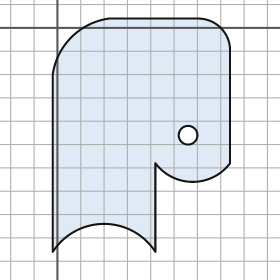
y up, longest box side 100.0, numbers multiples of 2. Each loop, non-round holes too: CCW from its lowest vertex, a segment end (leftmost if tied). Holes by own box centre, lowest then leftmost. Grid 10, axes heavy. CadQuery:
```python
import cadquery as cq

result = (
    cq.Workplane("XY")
    .moveTo(-2.0, -96.0)
    .threePointArc((20.0, -84.0), (42.0, -96.0))
    .lineTo(42.0, -58.0)
    .threePointArc((58.0, -66.0), (74.0, -58.0))
    .lineTo(74.0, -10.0)
    .threePointArc((70.0, 0.0), (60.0, 4.0))
    .lineTo(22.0, 4.0)
    .threePointArc((6.0, -4.0), (-2.0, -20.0))
    .close()
    .moveTo(56.0, -46.0)
    .circle(4.0)
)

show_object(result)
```